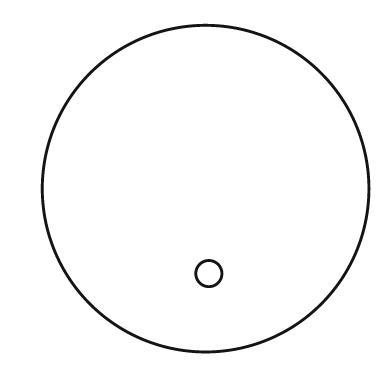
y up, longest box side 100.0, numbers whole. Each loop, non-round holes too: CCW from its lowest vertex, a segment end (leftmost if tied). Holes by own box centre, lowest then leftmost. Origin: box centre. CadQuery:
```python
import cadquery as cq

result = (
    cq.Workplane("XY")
    .moveTo(0.0, 0.0)
    .circle(50.0)
    .moveTo(1.0, -26.0)
    .circle(4.0)
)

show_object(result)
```